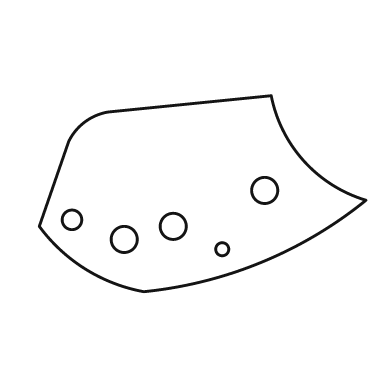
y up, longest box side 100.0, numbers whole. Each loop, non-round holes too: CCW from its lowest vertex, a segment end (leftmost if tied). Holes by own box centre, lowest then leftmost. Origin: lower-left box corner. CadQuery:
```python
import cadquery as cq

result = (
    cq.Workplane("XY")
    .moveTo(32.0, 0.0)
    .threePointArc((68.0, 9.0), (100.0, 28.0))
    .threePointArc((81.0, 40.0), (71.0, 60.0))
    .lineTo(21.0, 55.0)
    .threePointArc((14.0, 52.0), (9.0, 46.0))
    .lineTo(0.0, 20.0)
    .threePointArc((14.0, 7.0), (32.0, 0.0))
    .close()
    .moveTo(56.0, 13.0)
    .circle(2.0)
    .moveTo(26.0, 16.0)
    .circle(4.0)
    .moveTo(41.0, 20.0)
    .circle(4.0)
    .moveTo(10.0, 22.0)
    .circle(3.0)
    .moveTo(69.0, 31.0)
    .circle(4.0)
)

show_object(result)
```